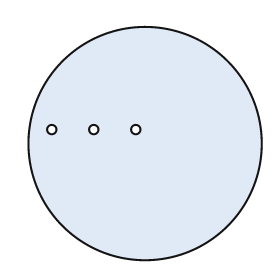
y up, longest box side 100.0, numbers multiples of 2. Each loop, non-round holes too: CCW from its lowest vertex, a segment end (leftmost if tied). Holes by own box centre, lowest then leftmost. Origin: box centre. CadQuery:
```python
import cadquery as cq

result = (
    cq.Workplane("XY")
    .moveTo(0.0, 0.0)
    .circle(50.0)
    .moveTo(-40.0, 6.0)
    .circle(2.0)
    .moveTo(-22.0, 6.0)
    .circle(2.0)
    .moveTo(-4.0, 6.0)
    .circle(2.0)
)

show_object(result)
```